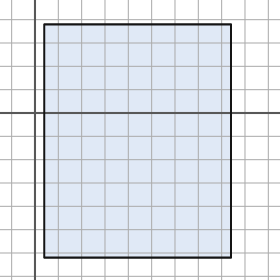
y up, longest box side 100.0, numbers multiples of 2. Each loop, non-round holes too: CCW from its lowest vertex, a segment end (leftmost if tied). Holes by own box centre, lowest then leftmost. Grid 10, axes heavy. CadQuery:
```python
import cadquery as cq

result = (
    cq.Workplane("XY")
    .moveTo(4.0, -62.0)
    .lineTo(84.0, -62.0)
    .lineTo(84.0, 38.0)
    .lineTo(4.0, 38.0)
    .close()
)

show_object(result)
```